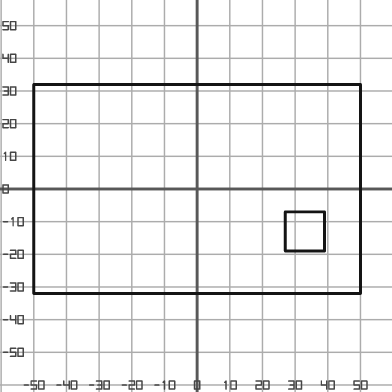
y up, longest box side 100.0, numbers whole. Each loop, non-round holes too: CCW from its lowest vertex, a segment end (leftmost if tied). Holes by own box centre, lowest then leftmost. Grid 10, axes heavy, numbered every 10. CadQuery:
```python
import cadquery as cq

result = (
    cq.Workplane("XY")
    .moveTo(-50.0, -32.0)
    .lineTo(50.0, -32.0)
    .lineTo(50.0, 32.0)
    .lineTo(-50.0, 32.0)
    .close()
    .moveTo(27.0, -19.0)
    .lineTo(39.0, -19.0)
    .lineTo(39.0, -7.0)
    .lineTo(27.0, -7.0)
    .close()
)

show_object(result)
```